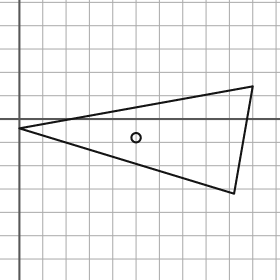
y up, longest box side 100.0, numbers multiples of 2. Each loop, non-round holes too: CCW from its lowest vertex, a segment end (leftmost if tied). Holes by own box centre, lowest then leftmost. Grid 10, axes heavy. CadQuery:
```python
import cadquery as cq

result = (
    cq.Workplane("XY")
    .moveTo(92.0, -32.0)
    .lineTo(100.0, 14.0)
    .lineTo(0.0, -4.0)
    .close()
    .moveTo(50.0, -8.0)
    .circle(2.0)
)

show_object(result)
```